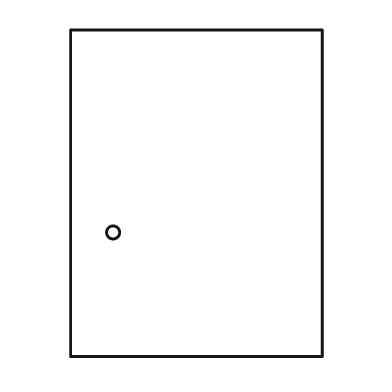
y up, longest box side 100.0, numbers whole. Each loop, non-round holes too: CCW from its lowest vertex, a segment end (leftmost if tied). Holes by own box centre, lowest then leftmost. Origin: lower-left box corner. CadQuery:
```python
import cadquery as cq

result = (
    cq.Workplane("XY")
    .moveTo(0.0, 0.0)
    .lineTo(77.0, 0.0)
    .lineTo(77.0, 100.0)
    .lineTo(0.0, 100.0)
    .close()
    .moveTo(13.0, 38.0)
    .circle(2.0)
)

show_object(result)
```